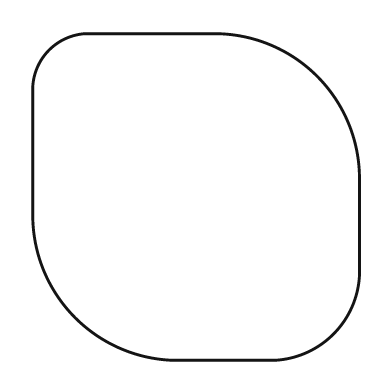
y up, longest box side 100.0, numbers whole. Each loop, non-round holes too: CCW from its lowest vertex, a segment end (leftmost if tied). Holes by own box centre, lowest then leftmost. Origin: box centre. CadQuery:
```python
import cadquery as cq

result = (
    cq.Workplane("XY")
    .moveTo(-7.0, -50.0)
    .lineTo(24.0, -50.0)
    .threePointArc((42.0, -42.0), (50.0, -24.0))
    .lineTo(50.0, 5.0)
    .threePointArc((37.0, 37.0), (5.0, 50.0))
    .lineTo(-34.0, 50.0)
    .threePointArc((-45.0, 45.0), (-50.0, 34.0))
    .lineTo(-50.0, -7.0)
    .threePointArc((-37.0, -37.0), (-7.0, -50.0))
    .close()
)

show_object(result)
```